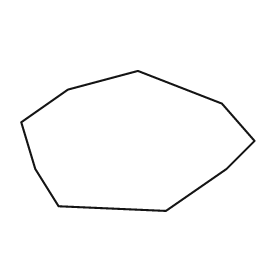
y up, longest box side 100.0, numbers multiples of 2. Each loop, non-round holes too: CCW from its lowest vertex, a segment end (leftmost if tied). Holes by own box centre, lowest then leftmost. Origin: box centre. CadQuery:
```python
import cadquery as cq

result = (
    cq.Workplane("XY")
    .moveTo(12.0, -30.0)
    .lineTo(38.0, -12.0)
    .lineTo(50.0, 0.0)
    .lineTo(36.0, 16.0)
    .lineTo(0.0, 30.0)
    .lineTo(-30.0, 22.0)
    .lineTo(-50.0, 8.0)
    .lineTo(-44.0, -12.0)
    .lineTo(-34.0, -28.0)
    .close()
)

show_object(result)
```